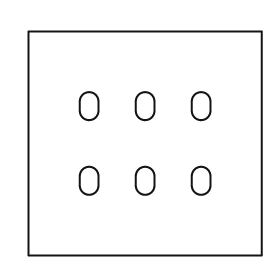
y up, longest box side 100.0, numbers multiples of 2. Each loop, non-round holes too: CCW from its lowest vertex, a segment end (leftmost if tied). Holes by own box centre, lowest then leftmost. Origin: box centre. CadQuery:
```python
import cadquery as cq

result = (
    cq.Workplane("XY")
    .moveTo(-50.0, -48.0)
    .lineTo(50.0, -48.0)
    .lineTo(50.0, 48.0)
    .lineTo(-50.0, 48.0)
    .close()
    .moveTo(-28.0, -18.0)
    .threePointArc((-24.0, -22.0), (-20.0, -18.0))
    .lineTo(-20.0, -14.0)
    .threePointArc((-24.0, -10.0), (-28.0, -14.0))
    .close()
    .moveTo(-4.0, -18.0)
    .threePointArc((0.0, -22.0), (4.0, -18.0))
    .lineTo(4.0, -14.0)
    .threePointArc((0.0, -10.0), (-4.0, -14.0))
    .close()
    .moveTo(20.0, -18.0)
    .threePointArc((24.0, -22.0), (28.0, -18.0))
    .lineTo(28.0, -14.0)
    .threePointArc((24.0, -10.0), (20.0, -14.0))
    .close()
    .moveTo(-28.0, 14.0)
    .threePointArc((-24.0, 10.0), (-20.0, 14.0))
    .lineTo(-20.0, 18.0)
    .threePointArc((-24.0, 22.0), (-28.0, 18.0))
    .close()
    .moveTo(-4.0, 14.0)
    .threePointArc((0.0, 10.0), (4.0, 14.0))
    .lineTo(4.0, 18.0)
    .threePointArc((0.0, 22.0), (-4.0, 18.0))
    .close()
    .moveTo(20.0, 14.0)
    .threePointArc((24.0, 10.0), (28.0, 14.0))
    .lineTo(28.0, 18.0)
    .threePointArc((24.0, 22.0), (20.0, 18.0))
    .close()
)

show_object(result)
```